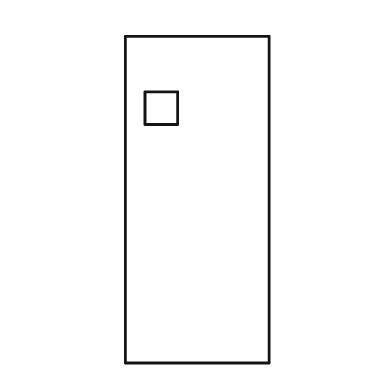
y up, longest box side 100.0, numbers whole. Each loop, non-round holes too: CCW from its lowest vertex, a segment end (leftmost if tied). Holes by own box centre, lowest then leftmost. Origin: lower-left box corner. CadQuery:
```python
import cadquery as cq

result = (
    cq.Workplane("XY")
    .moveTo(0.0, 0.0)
    .lineTo(44.0, 0.0)
    .lineTo(44.0, 100.0)
    .lineTo(0.0, 100.0)
    .close()
    .moveTo(6.0, 73.0)
    .lineTo(16.0, 73.0)
    .lineTo(16.0, 83.0)
    .lineTo(6.0, 83.0)
    .close()
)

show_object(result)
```